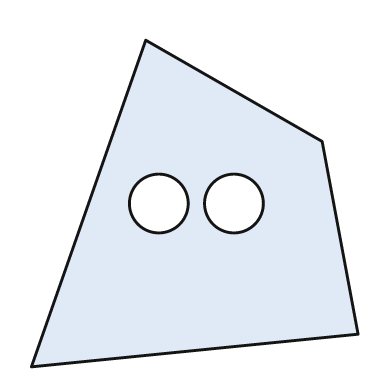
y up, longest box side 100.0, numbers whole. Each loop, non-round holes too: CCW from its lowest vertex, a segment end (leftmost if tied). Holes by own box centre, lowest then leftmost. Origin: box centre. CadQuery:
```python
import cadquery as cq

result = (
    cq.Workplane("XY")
    .moveTo(-50.0, -50.0)
    .lineTo(50.0, -40.0)
    .lineTo(39.0, 19.0)
    .lineTo(-15.0, 50.0)
    .close()
    .moveTo(-11.0, 0.0)
    .circle(9.0)
    .moveTo(12.0, 0.0)
    .circle(9.0)
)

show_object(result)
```